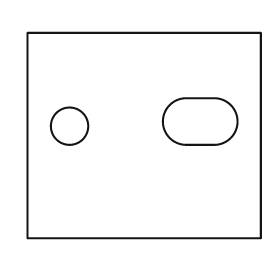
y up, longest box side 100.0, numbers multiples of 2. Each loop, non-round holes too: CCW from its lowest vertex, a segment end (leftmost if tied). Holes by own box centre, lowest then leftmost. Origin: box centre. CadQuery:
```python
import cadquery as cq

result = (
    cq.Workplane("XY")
    .moveTo(-50.0, -44.0)
    .lineTo(50.0, -44.0)
    .lineTo(50.0, 44.0)
    .lineTo(-50.0, 44.0)
    .close()
    .moveTo(-32.0, 4.0)
    .circle(8.0)
    .moveTo(18.0, -4.0)
    .lineTo(30.0, -4.0)
    .threePointArc((40.0, 6.0), (30.0, 16.0))
    .lineTo(18.0, 16.0)
    .threePointArc((8.0, 6.0), (18.0, -4.0))
    .close()
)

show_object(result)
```